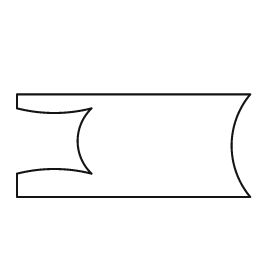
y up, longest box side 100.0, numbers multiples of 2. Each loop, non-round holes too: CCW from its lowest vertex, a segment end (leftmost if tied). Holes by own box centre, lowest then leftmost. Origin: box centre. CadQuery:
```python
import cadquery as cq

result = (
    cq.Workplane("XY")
    .moveTo(-50.0, -22.0)
    .lineTo(50.0, -22.0)
    .threePointArc((42.0, 0.0), (50.0, 22.0))
    .lineTo(-50.0, 22.0)
    .lineTo(-50.0, 16.0)
    .threePointArc((-34.0, 14.0), (-18.0, 16.0))
    .threePointArc((-24.0, 2.0), (-18.0, -12.0))
    .threePointArc((-34.0, -10.0), (-50.0, -12.0))
    .close()
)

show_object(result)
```